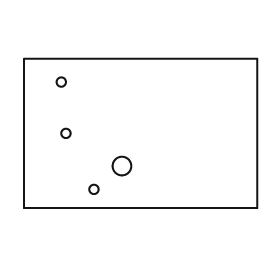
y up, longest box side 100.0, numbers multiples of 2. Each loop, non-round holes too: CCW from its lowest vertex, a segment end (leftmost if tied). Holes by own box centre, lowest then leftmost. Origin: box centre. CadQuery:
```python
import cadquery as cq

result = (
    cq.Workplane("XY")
    .moveTo(-50.0, -32.0)
    .lineTo(50.0, -32.0)
    .lineTo(50.0, 32.0)
    .lineTo(-50.0, 32.0)
    .close()
    .moveTo(-20.0, -24.0)
    .circle(2.0)
    .moveTo(-8.0, -14.0)
    .circle(4.0)
    .moveTo(-32.0, 0.0)
    .circle(2.0)
    .moveTo(-34.0, 22.0)
    .circle(2.0)
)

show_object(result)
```